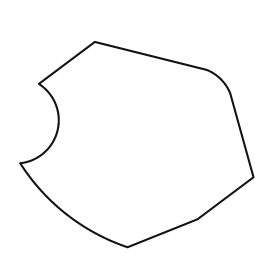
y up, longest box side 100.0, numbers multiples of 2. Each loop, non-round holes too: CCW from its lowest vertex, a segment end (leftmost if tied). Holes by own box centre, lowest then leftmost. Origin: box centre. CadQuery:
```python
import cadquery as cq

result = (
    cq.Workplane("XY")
    .moveTo(-4.0, -44.0)
    .lineTo(26.0, -32.0)
    .lineTo(50.0, -14.0)
    .lineTo(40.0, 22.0)
    .threePointArc((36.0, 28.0), (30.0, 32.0))
    .lineTo(-18.0, 44.0)
    .lineTo(-42.0, 26.0)
    .threePointArc((-34.0, 6.0), (-50.0, -8.0))
    .threePointArc((-30.0, -30.0), (-4.0, -44.0))
    .close()
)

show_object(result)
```